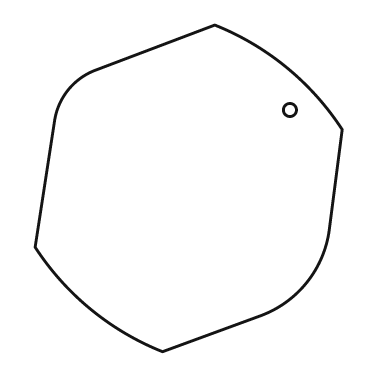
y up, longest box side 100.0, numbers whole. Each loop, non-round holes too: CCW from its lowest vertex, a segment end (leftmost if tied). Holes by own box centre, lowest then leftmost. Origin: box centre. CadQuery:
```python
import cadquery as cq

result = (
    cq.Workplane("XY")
    .moveTo(-8.0, -50.0)
    .lineTo(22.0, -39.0)
    .threePointArc((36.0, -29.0), (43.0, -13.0))
    .lineTo(47.0, 18.0)
    .threePointArc((30.0, 37.0), (8.0, 50.0))
    .lineTo(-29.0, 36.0)
    .threePointArc((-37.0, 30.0), (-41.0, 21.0))
    .lineTo(-47.0, -18.0)
    .threePointArc((-30.0, -37.0), (-8.0, -50.0))
    .close()
    .moveTo(31.0, 24.0)
    .circle(2.0)
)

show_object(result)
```